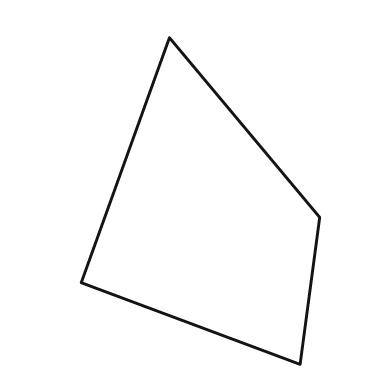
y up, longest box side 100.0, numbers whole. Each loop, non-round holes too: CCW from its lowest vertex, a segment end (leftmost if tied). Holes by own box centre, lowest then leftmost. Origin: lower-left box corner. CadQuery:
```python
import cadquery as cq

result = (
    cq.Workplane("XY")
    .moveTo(67.0, 0.0)
    .lineTo(73.0, 45.0)
    .lineTo(27.0, 100.0)
    .lineTo(0.0, 25.0)
    .close()
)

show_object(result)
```